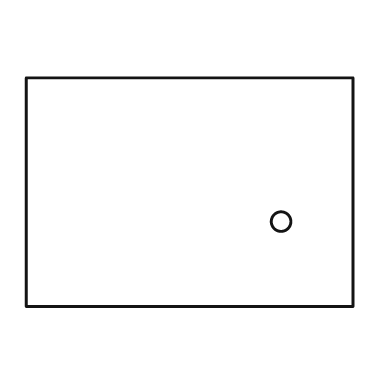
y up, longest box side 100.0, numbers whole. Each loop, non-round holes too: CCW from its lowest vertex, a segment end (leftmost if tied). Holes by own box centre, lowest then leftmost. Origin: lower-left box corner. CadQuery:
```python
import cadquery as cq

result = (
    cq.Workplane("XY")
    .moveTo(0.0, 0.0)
    .lineTo(100.0, 0.0)
    .lineTo(100.0, 70.0)
    .lineTo(0.0, 70.0)
    .close()
    .moveTo(78.0, 26.0)
    .circle(3.0)
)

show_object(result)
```